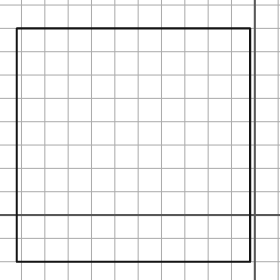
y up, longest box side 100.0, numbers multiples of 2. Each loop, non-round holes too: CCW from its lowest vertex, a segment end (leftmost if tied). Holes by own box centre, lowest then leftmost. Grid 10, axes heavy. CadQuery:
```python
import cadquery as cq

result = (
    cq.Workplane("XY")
    .moveTo(-102.0, -20.0)
    .lineTo(-2.0, -20.0)
    .lineTo(-2.0, 80.0)
    .lineTo(-102.0, 80.0)
    .close()
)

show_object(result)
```